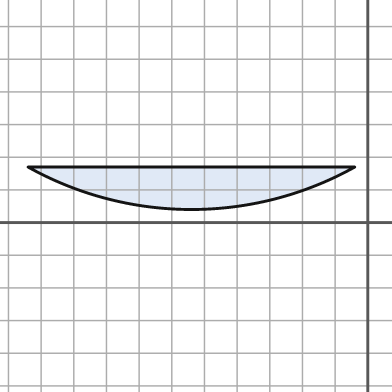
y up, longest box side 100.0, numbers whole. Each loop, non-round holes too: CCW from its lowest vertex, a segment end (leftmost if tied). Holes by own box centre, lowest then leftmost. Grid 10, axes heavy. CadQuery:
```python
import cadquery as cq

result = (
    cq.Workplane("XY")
    .moveTo(-104.0, 17.0)
    .threePointArc((-54.0, 4.0), (-4.0, 17.0))
    .close()
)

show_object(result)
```